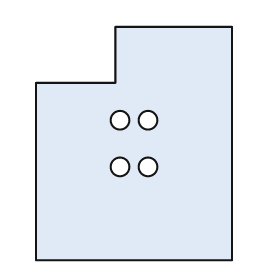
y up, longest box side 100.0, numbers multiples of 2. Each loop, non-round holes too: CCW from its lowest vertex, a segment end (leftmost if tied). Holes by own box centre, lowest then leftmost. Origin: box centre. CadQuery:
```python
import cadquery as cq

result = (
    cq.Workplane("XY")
    .moveTo(-42.0, -50.0)
    .lineTo(42.0, -50.0)
    .lineTo(42.0, 50.0)
    .lineTo(-8.0, 50.0)
    .lineTo(-8.0, 26.0)
    .lineTo(-42.0, 26.0)
    .close()
    .moveTo(-6.0, -10.0)
    .circle(4.0)
    .moveTo(6.0, -10.0)
    .circle(4.0)
    .moveTo(-6.0, 10.0)
    .circle(4.0)
    .moveTo(6.0, 10.0)
    .circle(4.0)
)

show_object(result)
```